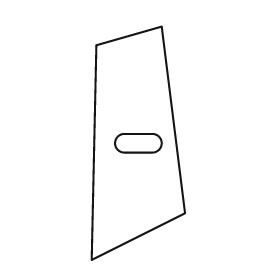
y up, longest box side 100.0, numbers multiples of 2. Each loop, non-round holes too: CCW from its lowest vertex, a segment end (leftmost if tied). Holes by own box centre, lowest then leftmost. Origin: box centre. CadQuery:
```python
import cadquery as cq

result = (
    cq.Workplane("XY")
    .moveTo(-20.0, -50.0)
    .lineTo(20.0, -30.0)
    .lineTo(10.0, 50.0)
    .lineTo(-18.0, 42.0)
    .close()
    .moveTo(-6.0, -4.0)
    .lineTo(6.0, -4.0)
    .threePointArc((10.0, 0.0), (6.0, 4.0))
    .lineTo(-6.0, 4.0)
    .threePointArc((-10.0, 0.0), (-6.0, -4.0))
    .close()
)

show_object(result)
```